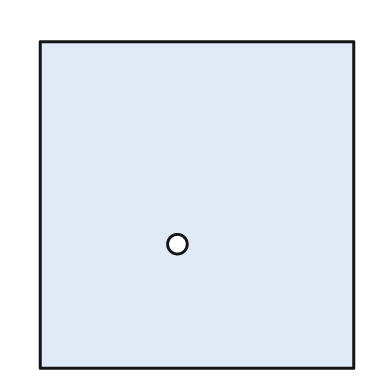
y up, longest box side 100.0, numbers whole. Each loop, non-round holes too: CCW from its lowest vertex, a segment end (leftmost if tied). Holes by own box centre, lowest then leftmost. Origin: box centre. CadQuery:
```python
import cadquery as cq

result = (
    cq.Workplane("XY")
    .moveTo(-48.0, -50.0)
    .lineTo(48.0, -50.0)
    .lineTo(48.0, 50.0)
    .lineTo(-48.0, 50.0)
    .close()
    .moveTo(-6.0, -12.0)
    .circle(3.0)
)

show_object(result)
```